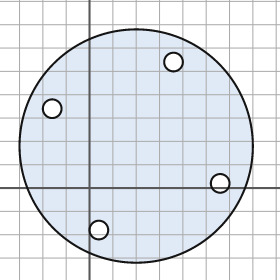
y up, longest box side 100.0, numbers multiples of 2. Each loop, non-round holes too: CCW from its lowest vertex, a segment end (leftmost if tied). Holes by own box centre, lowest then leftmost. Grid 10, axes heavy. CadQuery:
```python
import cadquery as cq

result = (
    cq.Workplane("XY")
    .moveTo(20.0, 18.0)
    .circle(50.0)
    .moveTo(4.0, -18.0)
    .circle(4.0)
    .moveTo(56.0, 2.0)
    .circle(4.0)
    .moveTo(-16.0, 34.0)
    .circle(4.0)
    .moveTo(36.0, 54.0)
    .circle(4.0)
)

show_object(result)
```